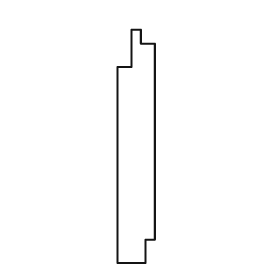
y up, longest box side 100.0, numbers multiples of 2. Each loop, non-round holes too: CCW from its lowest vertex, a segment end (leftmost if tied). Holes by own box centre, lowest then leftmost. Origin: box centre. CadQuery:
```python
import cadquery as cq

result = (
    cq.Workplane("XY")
    .moveTo(-8.0, -50.0)
    .lineTo(4.0, -50.0)
    .lineTo(4.0, -40.0)
    .lineTo(8.0, -40.0)
    .lineTo(8.0, 44.0)
    .lineTo(2.0, 44.0)
    .lineTo(2.0, 50.0)
    .lineTo(-2.0, 50.0)
    .lineTo(-2.0, 34.0)
    .lineTo(-8.0, 34.0)
    .close()
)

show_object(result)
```